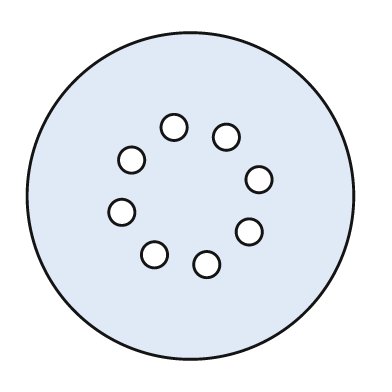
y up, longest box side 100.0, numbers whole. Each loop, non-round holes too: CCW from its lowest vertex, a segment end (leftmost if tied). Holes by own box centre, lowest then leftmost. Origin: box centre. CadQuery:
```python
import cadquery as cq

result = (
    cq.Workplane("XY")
    .moveTo(0.0, 0.0)
    .circle(50.0)
    .moveTo(5.0, -21.0)
    .circle(4.0)
    .moveTo(-11.0, -18.0)
    .circle(4.0)
    .moveTo(18.0, -11.0)
    .circle(4.0)
    .moveTo(-21.0, -5.0)
    .circle(4.0)
    .moveTo(21.0, 5.0)
    .circle(4.0)
    .moveTo(-18.0, 11.0)
    .circle(4.0)
    .moveTo(11.0, 18.0)
    .circle(4.0)
    .moveTo(-5.0, 21.0)
    .circle(4.0)
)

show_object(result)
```